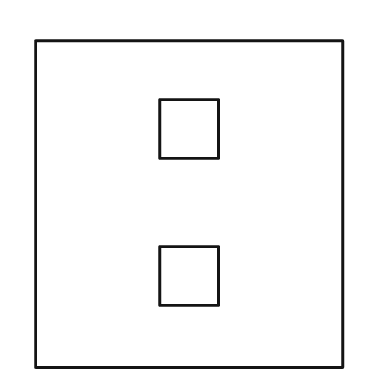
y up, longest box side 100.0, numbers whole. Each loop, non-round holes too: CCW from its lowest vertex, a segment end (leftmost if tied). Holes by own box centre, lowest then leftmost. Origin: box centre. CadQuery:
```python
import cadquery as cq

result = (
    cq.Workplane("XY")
    .moveTo(-47.0, -50.0)
    .lineTo(47.0, -50.0)
    .lineTo(47.0, 50.0)
    .lineTo(-47.0, 50.0)
    .close()
    .moveTo(-9.0, -31.0)
    .lineTo(9.0, -31.0)
    .lineTo(9.0, -13.0)
    .lineTo(-9.0, -13.0)
    .close()
    .moveTo(-9.0, 14.0)
    .lineTo(9.0, 14.0)
    .lineTo(9.0, 32.0)
    .lineTo(-9.0, 32.0)
    .close()
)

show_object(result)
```